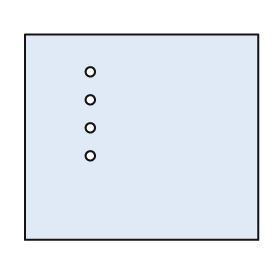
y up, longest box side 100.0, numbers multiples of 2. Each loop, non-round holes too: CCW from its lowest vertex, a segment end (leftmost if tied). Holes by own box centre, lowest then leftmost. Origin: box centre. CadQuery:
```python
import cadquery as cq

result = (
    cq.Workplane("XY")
    .moveTo(-50.0, -44.0)
    .lineTo(50.0, -44.0)
    .lineTo(50.0, 44.0)
    .lineTo(-50.0, 44.0)
    .close()
    .moveTo(-22.0, -8.0)
    .circle(2.0)
    .moveTo(-22.0, 4.0)
    .circle(2.0)
    .moveTo(-22.0, 16.0)
    .circle(2.0)
    .moveTo(-22.0, 28.0)
    .circle(2.0)
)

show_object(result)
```